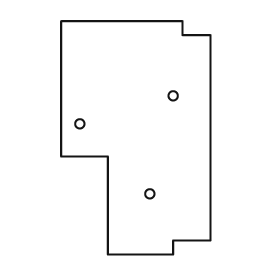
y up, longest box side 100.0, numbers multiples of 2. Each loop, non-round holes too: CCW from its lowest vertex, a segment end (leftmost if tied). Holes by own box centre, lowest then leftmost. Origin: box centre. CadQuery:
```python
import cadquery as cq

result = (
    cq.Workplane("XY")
    .moveTo(-12.0, -50.0)
    .lineTo(16.0, -50.0)
    .lineTo(16.0, -44.0)
    .lineTo(32.0, -44.0)
    .lineTo(32.0, 44.0)
    .lineTo(20.0, 44.0)
    .lineTo(20.0, 50.0)
    .lineTo(-32.0, 50.0)
    .lineTo(-32.0, -8.0)
    .lineTo(-12.0, -8.0)
    .close()
    .moveTo(6.0, -24.0)
    .circle(2.0)
    .moveTo(-24.0, 6.0)
    .circle(2.0)
    .moveTo(16.0, 18.0)
    .circle(2.0)
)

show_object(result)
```